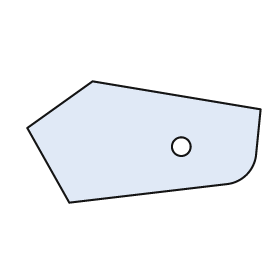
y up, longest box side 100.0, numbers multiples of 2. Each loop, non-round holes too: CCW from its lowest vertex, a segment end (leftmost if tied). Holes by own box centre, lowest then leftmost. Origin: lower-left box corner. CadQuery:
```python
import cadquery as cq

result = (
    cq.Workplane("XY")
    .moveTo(18.0, 0.0)
    .lineTo(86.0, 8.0)
    .threePointArc((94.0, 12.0), (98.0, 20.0))
    .lineTo(100.0, 40.0)
    .lineTo(28.0, 52.0)
    .lineTo(0.0, 32.0)
    .close()
    .moveTo(66.0, 24.0)
    .circle(4.0)
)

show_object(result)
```